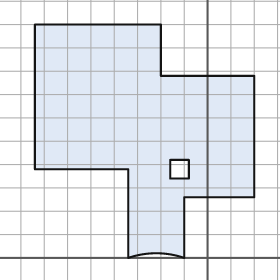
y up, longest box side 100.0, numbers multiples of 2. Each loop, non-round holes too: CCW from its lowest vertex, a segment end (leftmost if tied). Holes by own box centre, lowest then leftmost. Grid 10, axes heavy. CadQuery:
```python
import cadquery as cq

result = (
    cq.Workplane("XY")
    .moveTo(-34.0, 0.0)
    .threePointArc((-22.0, 2.0), (-10.0, 0.0))
    .lineTo(-10.0, 26.0)
    .lineTo(20.0, 26.0)
    .lineTo(20.0, 78.0)
    .lineTo(-20.0, 78.0)
    .lineTo(-20.0, 100.0)
    .lineTo(-74.0, 100.0)
    .lineTo(-74.0, 38.0)
    .lineTo(-34.0, 38.0)
    .close()
    .moveTo(-16.0, 34.0)
    .lineTo(-8.0, 34.0)
    .lineTo(-8.0, 42.0)
    .lineTo(-16.0, 42.0)
    .close()
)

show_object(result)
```